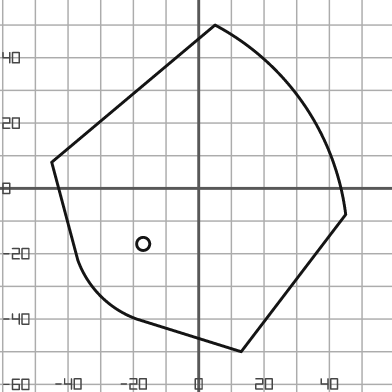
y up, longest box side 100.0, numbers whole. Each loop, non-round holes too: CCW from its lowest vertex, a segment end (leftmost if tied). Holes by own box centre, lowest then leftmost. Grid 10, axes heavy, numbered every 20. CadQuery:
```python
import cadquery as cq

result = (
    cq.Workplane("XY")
    .moveTo(13.0, -50.0)
    .lineTo(45.0, -8.0)
    .threePointArc((32.0, 26.0), (5.0, 50.0))
    .lineTo(-45.0, 8.0)
    .lineTo(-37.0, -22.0)
    .threePointArc((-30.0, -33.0), (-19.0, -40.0))
    .close()
    .moveTo(-17.0, -17.0)
    .circle(2.0)
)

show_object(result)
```